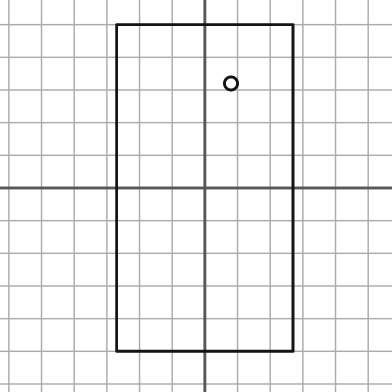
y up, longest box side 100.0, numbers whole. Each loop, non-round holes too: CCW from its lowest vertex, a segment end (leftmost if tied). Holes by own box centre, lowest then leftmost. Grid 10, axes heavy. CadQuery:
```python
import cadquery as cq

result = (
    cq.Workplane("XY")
    .moveTo(-27.0, -50.0)
    .lineTo(27.0, -50.0)
    .lineTo(27.0, 50.0)
    .lineTo(-27.0, 50.0)
    .close()
    .moveTo(8.0, 32.0)
    .circle(2.0)
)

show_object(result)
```